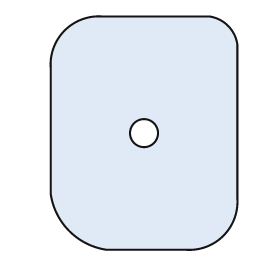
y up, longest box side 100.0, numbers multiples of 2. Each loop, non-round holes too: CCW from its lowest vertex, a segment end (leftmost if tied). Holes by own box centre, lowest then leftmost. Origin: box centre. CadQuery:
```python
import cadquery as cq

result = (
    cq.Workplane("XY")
    .moveTo(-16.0, -50.0)
    .lineTo(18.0, -50.0)
    .threePointArc((34.0, -44.0), (40.0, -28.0))
    .lineTo(40.0, 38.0)
    .threePointArc((36.0, 46.0), (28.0, 50.0))
    .lineTo(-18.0, 50.0)
    .threePointArc((-34.0, 44.0), (-40.0, 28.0))
    .lineTo(-40.0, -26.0)
    .threePointArc((-32.0, -42.0), (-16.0, -50.0))
    .close()
    .moveTo(0.0, 0.0)
    .circle(6.0)
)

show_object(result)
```